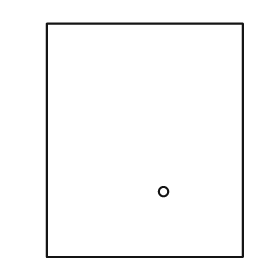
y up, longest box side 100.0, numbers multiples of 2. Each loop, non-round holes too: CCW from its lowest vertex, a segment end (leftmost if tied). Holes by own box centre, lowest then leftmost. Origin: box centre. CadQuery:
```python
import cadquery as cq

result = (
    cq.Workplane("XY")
    .moveTo(-42.0, -50.0)
    .lineTo(42.0, -50.0)
    .lineTo(42.0, 50.0)
    .lineTo(-42.0, 50.0)
    .close()
    .moveTo(8.0, -22.0)
    .circle(2.0)
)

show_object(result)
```